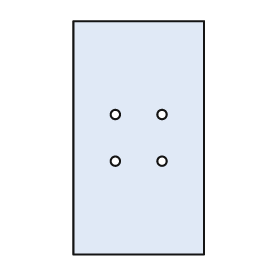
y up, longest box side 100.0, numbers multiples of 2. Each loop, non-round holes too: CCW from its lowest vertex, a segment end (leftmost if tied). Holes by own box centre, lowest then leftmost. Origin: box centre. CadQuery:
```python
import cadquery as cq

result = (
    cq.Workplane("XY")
    .moveTo(-28.0, -50.0)
    .lineTo(28.0, -50.0)
    .lineTo(28.0, 50.0)
    .lineTo(-28.0, 50.0)
    .close()
    .moveTo(-10.0, -10.0)
    .circle(2.0)
    .moveTo(10.0, -10.0)
    .circle(2.0)
    .moveTo(-10.0, 10.0)
    .circle(2.0)
    .moveTo(10.0, 10.0)
    .circle(2.0)
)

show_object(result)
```